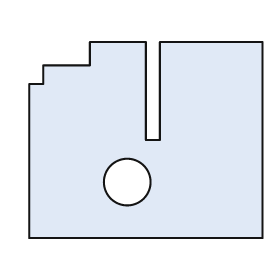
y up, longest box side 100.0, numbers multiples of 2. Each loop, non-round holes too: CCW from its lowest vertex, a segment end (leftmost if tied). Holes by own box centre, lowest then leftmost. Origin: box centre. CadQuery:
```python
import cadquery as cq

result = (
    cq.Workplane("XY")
    .moveTo(-50.0, -42.0)
    .lineTo(50.0, -42.0)
    .lineTo(50.0, 42.0)
    .lineTo(6.0, 42.0)
    .lineTo(6.0, 0.0)
    .lineTo(0.0, 0.0)
    .lineTo(0.0, 42.0)
    .lineTo(-24.0, 42.0)
    .lineTo(-24.0, 32.0)
    .lineTo(-44.0, 32.0)
    .lineTo(-44.0, 24.0)
    .lineTo(-50.0, 24.0)
    .close()
    .moveTo(-8.0, -18.0)
    .circle(10.0)
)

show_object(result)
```